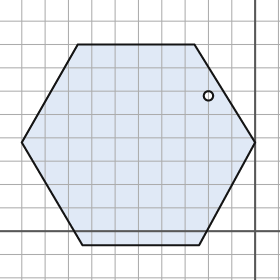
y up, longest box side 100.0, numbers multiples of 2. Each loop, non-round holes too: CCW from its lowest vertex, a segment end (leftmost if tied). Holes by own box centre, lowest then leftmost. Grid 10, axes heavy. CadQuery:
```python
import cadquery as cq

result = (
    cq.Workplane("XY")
    .moveTo(-74.0, -6.0)
    .lineTo(-24.0, -6.0)
    .lineTo(0.0, 38.0)
    .lineTo(-26.0, 80.0)
    .lineTo(-76.0, 80.0)
    .lineTo(-100.0, 38.0)
    .close()
    .moveTo(-20.0, 58.0)
    .circle(2.0)
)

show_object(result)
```